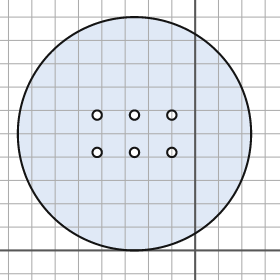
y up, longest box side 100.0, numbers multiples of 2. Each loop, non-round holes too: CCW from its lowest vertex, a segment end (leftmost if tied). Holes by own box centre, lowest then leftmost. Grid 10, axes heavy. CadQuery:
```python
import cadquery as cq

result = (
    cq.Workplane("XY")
    .moveTo(-26.0, 50.0)
    .circle(50.0)
    .moveTo(-42.0, 42.0)
    .circle(2.0)
    .moveTo(-26.0, 42.0)
    .circle(2.0)
    .moveTo(-10.0, 42.0)
    .circle(2.0)
    .moveTo(-42.0, 58.0)
    .circle(2.0)
    .moveTo(-26.0, 58.0)
    .circle(2.0)
    .moveTo(-10.0, 58.0)
    .circle(2.0)
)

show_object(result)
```